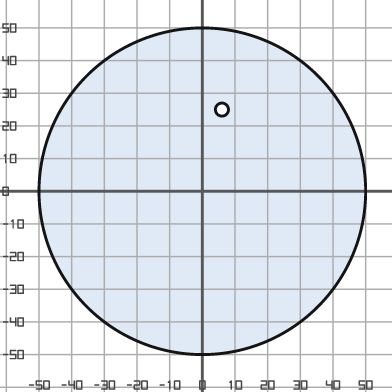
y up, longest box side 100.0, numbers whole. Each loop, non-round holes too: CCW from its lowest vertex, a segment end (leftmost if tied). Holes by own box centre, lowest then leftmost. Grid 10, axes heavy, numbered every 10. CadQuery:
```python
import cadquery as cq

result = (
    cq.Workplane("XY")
    .moveTo(0.0, 0.0)
    .circle(50.0)
    .moveTo(6.0, 25.0)
    .circle(2.0)
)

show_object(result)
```